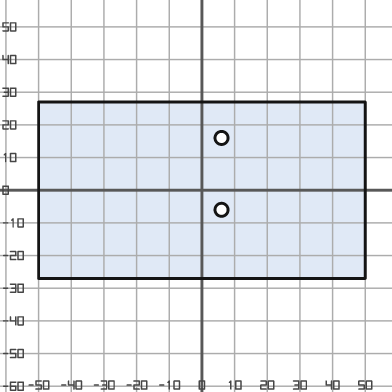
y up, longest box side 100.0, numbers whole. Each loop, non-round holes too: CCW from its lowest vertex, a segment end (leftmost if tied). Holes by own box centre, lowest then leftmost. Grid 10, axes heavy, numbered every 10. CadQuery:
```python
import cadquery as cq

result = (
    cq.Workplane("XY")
    .moveTo(-50.0, -27.0)
    .lineTo(50.0, -27.0)
    .lineTo(50.0, 27.0)
    .lineTo(-50.0, 27.0)
    .close()
    .moveTo(6.0, -6.0)
    .circle(2.0)
    .moveTo(6.0, 16.0)
    .circle(2.0)
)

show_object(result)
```